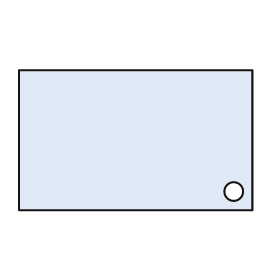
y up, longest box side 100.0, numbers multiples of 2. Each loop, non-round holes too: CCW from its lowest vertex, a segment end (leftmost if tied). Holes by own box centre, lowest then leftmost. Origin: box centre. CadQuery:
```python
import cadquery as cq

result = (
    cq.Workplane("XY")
    .moveTo(-50.0, -30.0)
    .lineTo(50.0, -30.0)
    .lineTo(50.0, 30.0)
    .lineTo(-50.0, 30.0)
    .close()
    .moveTo(42.0, -22.0)
    .circle(4.0)
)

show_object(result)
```